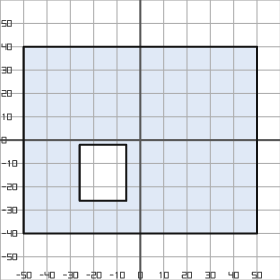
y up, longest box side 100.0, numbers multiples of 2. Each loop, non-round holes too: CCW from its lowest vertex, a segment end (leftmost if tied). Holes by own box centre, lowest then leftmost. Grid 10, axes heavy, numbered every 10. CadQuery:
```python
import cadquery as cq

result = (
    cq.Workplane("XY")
    .moveTo(-50.0, -40.0)
    .lineTo(50.0, -40.0)
    .lineTo(50.0, 40.0)
    .lineTo(-50.0, 40.0)
    .close()
    .moveTo(-26.0, -26.0)
    .lineTo(-6.0, -26.0)
    .lineTo(-6.0, -2.0)
    .lineTo(-26.0, -2.0)
    .close()
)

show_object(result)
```